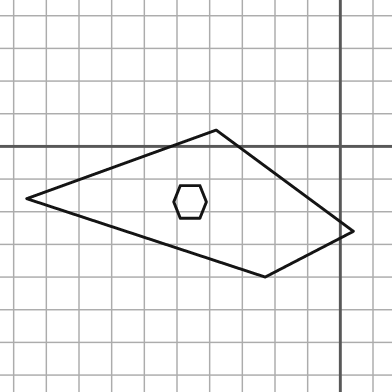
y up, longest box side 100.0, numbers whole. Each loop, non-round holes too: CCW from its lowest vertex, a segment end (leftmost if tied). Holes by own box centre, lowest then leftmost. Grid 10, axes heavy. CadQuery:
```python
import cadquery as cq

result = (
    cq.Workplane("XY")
    .moveTo(-23.0, -40.0)
    .lineTo(4.0, -26.0)
    .lineTo(-38.0, 5.0)
    .lineTo(-96.0, -16.0)
    .close()
    .moveTo(-49.0, -22.0)
    .lineTo(-43.0, -22.0)
    .lineTo(-41.0, -17.0)
    .lineTo(-43.0, -12.0)
    .lineTo(-49.0, -12.0)
    .lineTo(-51.0, -17.0)
    .close()
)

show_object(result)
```